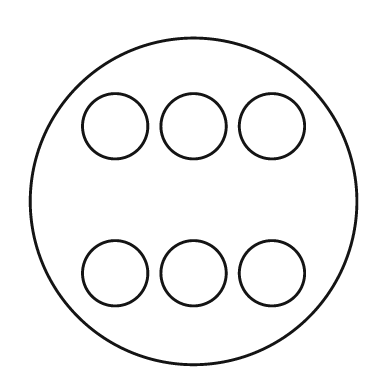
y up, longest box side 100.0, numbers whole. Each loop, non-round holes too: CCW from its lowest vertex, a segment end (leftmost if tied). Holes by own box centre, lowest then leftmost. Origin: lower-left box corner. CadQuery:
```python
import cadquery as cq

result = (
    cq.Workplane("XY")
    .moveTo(50.0, 50.0)
    .circle(50.0)
    .moveTo(26.0, 28.0)
    .circle(10.0)
    .moveTo(50.0, 28.0)
    .circle(10.0)
    .moveTo(74.0, 28.0)
    .circle(10.0)
    .moveTo(26.0, 73.0)
    .circle(10.0)
    .moveTo(50.0, 73.0)
    .circle(10.0)
    .moveTo(74.0, 73.0)
    .circle(10.0)
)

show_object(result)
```